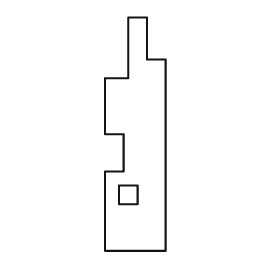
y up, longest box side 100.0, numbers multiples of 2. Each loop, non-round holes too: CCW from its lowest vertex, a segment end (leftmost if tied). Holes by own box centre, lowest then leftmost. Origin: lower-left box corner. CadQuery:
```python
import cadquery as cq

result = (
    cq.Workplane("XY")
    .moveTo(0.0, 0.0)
    .lineTo(26.0, 0.0)
    .lineTo(26.0, 82.0)
    .lineTo(18.0, 82.0)
    .lineTo(18.0, 100.0)
    .lineTo(10.0, 100.0)
    .lineTo(10.0, 74.0)
    .lineTo(0.0, 74.0)
    .lineTo(0.0, 50.0)
    .lineTo(8.0, 50.0)
    .lineTo(8.0, 34.0)
    .lineTo(0.0, 34.0)
    .close()
    .moveTo(6.0, 20.0)
    .lineTo(14.0, 20.0)
    .lineTo(14.0, 28.0)
    .lineTo(6.0, 28.0)
    .close()
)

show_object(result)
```